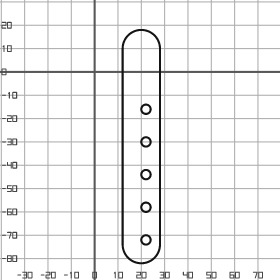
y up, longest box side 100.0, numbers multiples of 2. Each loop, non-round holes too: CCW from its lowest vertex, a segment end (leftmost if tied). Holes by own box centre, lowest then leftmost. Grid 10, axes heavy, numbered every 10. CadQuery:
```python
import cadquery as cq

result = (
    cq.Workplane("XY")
    .moveTo(12.0, -74.0)
    .threePointArc((20.0, -82.0), (28.0, -74.0))
    .lineTo(28.0, 10.0)
    .threePointArc((20.0, 18.0), (12.0, 10.0))
    .close()
    .moveTo(22.0, -72.0)
    .circle(2.0)
    .moveTo(22.0, -58.0)
    .circle(2.0)
    .moveTo(22.0, -44.0)
    .circle(2.0)
    .moveTo(22.0, -30.0)
    .circle(2.0)
    .moveTo(22.0, -16.0)
    .circle(2.0)
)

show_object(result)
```